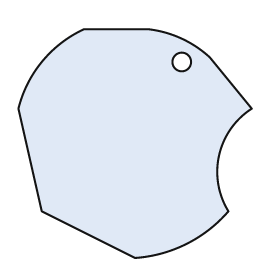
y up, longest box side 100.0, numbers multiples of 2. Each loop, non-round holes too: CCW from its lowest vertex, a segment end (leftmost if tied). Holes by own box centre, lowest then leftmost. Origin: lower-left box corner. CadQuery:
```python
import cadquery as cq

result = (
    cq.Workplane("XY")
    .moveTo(50.0, 0.0)
    .threePointArc((72.0, 6.0), (90.0, 20.0))
    .threePointArc((86.0, 44.0), (100.0, 64.0))
    .lineTo(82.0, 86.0)
    .threePointArc((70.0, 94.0), (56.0, 98.0))
    .lineTo(28.0, 98.0)
    .threePointArc((10.0, 84.0), (0.0, 64.0))
    .lineTo(10.0, 20.0)
    .close()
    .moveTo(70.0, 84.0)
    .circle(4.0)
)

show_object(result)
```